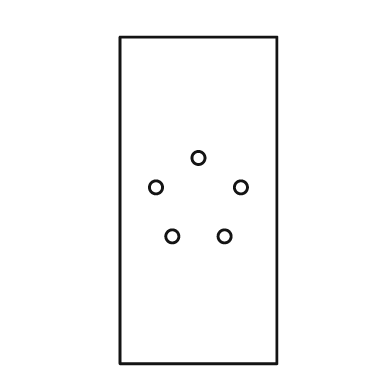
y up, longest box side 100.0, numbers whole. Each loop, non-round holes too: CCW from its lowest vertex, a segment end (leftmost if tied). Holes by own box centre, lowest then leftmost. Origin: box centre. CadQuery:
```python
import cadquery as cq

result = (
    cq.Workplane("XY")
    .moveTo(-24.0, -50.0)
    .lineTo(24.0, -50.0)
    .lineTo(24.0, 50.0)
    .lineTo(-24.0, 50.0)
    .close()
    .moveTo(-8.0, -11.0)
    .circle(2.0)
    .moveTo(8.0, -11.0)
    .circle(2.0)
    .moveTo(-13.0, 4.0)
    .circle(2.0)
    .moveTo(13.0, 4.0)
    .circle(2.0)
    .moveTo(0.0, 13.0)
    .circle(2.0)
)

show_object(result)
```